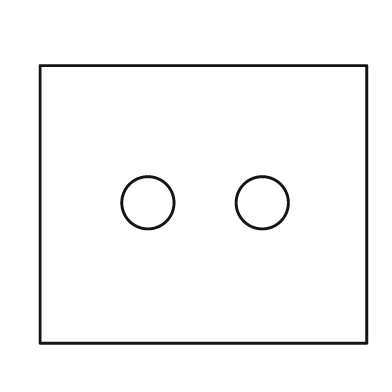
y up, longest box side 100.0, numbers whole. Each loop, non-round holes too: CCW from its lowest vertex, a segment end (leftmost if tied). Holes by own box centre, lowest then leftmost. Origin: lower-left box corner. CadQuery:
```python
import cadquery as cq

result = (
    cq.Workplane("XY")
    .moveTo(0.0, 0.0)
    .lineTo(100.0, 0.0)
    .lineTo(100.0, 85.0)
    .lineTo(0.0, 85.0)
    .close()
    .moveTo(33.0, 43.0)
    .circle(8.0)
    .moveTo(68.0, 43.0)
    .circle(8.0)
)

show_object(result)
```